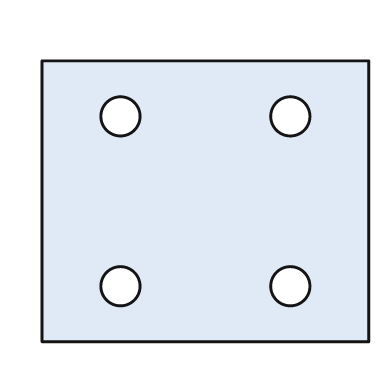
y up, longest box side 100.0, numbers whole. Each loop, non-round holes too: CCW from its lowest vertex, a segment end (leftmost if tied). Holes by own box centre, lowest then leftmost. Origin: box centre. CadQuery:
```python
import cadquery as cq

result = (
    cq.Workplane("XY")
    .moveTo(-50.0, -43.0)
    .lineTo(50.0, -43.0)
    .lineTo(50.0, 43.0)
    .lineTo(-50.0, 43.0)
    .close()
    .moveTo(-26.0, -26.0)
    .circle(6.0)
    .moveTo(26.0, -26.0)
    .circle(6.0)
    .moveTo(-26.0, 26.0)
    .circle(6.0)
    .moveTo(26.0, 26.0)
    .circle(6.0)
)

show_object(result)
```